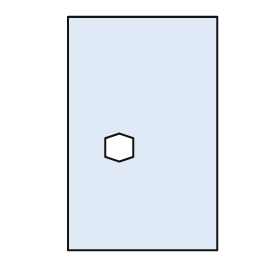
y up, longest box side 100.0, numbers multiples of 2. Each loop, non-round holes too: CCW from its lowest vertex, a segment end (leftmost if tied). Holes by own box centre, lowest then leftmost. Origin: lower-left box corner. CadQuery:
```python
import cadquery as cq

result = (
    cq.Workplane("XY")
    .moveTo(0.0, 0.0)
    .lineTo(64.0, 0.0)
    .lineTo(64.0, 100.0)
    .lineTo(0.0, 100.0)
    .close()
    .moveTo(22.0, 38.0)
    .lineTo(28.0, 40.0)
    .lineTo(28.0, 48.0)
    .lineTo(22.0, 50.0)
    .lineTo(16.0, 48.0)
    .lineTo(16.0, 40.0)
    .close()
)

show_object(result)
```